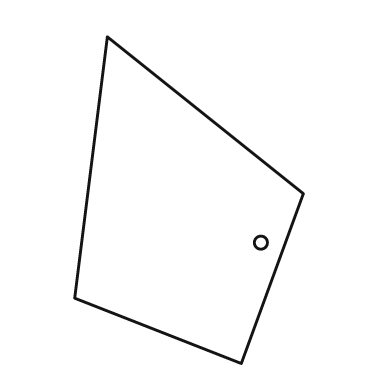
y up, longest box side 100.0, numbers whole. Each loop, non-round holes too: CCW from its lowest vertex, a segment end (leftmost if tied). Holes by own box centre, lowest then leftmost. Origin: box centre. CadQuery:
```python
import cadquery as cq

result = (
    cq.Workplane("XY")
    .moveTo(16.0, -50.0)
    .lineTo(35.0, 2.0)
    .lineTo(-25.0, 50.0)
    .lineTo(-35.0, -30.0)
    .close()
    .moveTo(22.0, -13.0)
    .circle(2.0)
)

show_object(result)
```